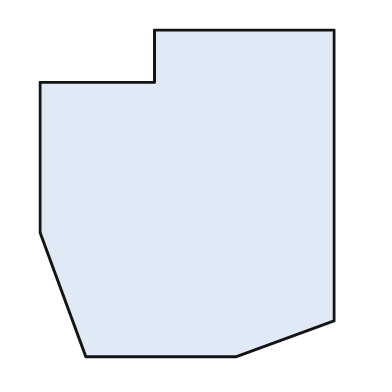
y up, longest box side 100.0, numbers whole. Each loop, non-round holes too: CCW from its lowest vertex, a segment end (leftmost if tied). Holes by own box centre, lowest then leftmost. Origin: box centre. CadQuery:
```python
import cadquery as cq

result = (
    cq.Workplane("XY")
    .moveTo(-31.0, -50.0)
    .lineTo(15.0, -50.0)
    .lineTo(45.0, -39.0)
    .lineTo(45.0, 50.0)
    .lineTo(-10.0, 50.0)
    .lineTo(-10.0, 34.0)
    .lineTo(-45.0, 34.0)
    .lineTo(-45.0, -12.0)
    .close()
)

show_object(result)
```